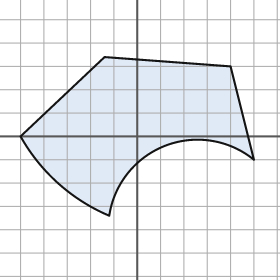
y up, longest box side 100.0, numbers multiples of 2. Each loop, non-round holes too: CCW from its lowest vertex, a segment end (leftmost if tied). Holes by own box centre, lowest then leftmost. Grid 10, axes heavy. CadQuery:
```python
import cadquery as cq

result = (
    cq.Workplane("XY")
    .moveTo(-12.0, -34.0)
    .threePointArc((12.0, -4.0), (50.0, -10.0))
    .lineTo(40.0, 30.0)
    .lineTo(-14.0, 34.0)
    .lineTo(-50.0, 0.0)
    .threePointArc((-34.0, -20.0), (-12.0, -34.0))
    .close()
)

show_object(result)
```